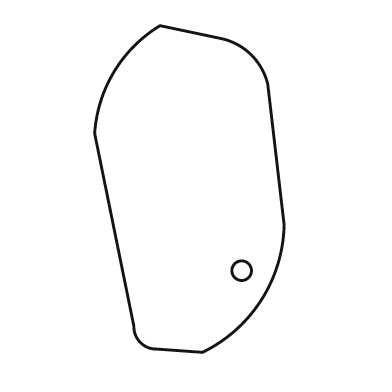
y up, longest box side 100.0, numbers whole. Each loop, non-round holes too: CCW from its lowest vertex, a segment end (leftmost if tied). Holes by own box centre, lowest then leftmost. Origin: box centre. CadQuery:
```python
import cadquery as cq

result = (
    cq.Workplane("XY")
    .moveTo(4.0, -50.0)
    .threePointArc((22.0, -34.0), (29.0, -11.0))
    .lineTo(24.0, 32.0)
    .threePointArc((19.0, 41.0), (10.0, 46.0))
    .lineTo(-9.0, 50.0)
    .threePointArc((-23.0, 36.0), (-29.0, 17.0))
    .lineTo(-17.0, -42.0)
    .threePointArc((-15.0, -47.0), (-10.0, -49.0))
    .close()
    .moveTo(16.0, -25.0)
    .circle(3.0)
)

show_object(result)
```